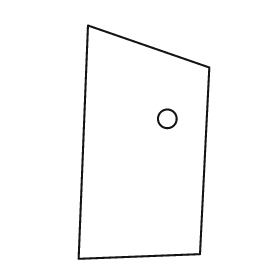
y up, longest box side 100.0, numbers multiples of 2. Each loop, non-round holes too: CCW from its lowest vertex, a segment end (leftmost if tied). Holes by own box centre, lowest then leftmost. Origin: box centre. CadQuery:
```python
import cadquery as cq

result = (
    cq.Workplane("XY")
    .moveTo(-28.0, -50.0)
    .lineTo(24.0, -48.0)
    .lineTo(28.0, 32.0)
    .lineTo(-24.0, 50.0)
    .close()
    .moveTo(10.0, 10.0)
    .circle(4.0)
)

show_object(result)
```